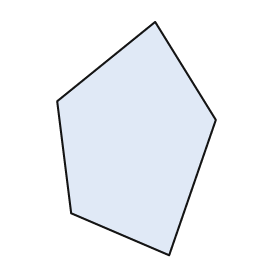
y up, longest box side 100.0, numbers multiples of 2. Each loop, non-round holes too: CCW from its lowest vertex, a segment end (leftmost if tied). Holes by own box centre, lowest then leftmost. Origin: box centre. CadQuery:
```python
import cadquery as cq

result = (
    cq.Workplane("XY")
    .moveTo(14.0, -50.0)
    .lineTo(34.0, 8.0)
    .lineTo(8.0, 50.0)
    .lineTo(-34.0, 16.0)
    .lineTo(-28.0, -32.0)
    .close()
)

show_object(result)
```